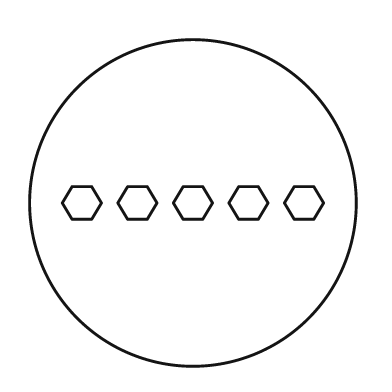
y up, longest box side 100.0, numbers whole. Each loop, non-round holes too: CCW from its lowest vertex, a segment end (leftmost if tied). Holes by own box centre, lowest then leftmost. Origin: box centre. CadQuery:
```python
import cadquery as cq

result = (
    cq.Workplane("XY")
    .moveTo(0.0, 0.0)
    .circle(50.0)
    .moveTo(-37.0, -5.0)
    .lineTo(-31.0, -5.0)
    .lineTo(-28.0, 0.0)
    .lineTo(-31.0, 5.0)
    .lineTo(-37.0, 5.0)
    .lineTo(-40.0, 0.0)
    .close()
    .moveTo(-20.0, -5.0)
    .lineTo(-14.0, -5.0)
    .lineTo(-11.0, 0.0)
    .lineTo(-14.0, 5.0)
    .lineTo(-20.0, 5.0)
    .lineTo(-23.0, 0.0)
    .close()
    .moveTo(-3.0, -5.0)
    .lineTo(3.0, -5.0)
    .lineTo(6.0, 0.0)
    .lineTo(3.0, 5.0)
    .lineTo(-3.0, 5.0)
    .lineTo(-6.0, 0.0)
    .close()
    .moveTo(14.0, -5.0)
    .lineTo(20.0, -5.0)
    .lineTo(23.0, 0.0)
    .lineTo(20.0, 5.0)
    .lineTo(14.0, 5.0)
    .lineTo(11.0, 0.0)
    .close()
    .moveTo(31.0, -5.0)
    .lineTo(37.0, -5.0)
    .lineTo(40.0, 0.0)
    .lineTo(37.0, 5.0)
    .lineTo(31.0, 5.0)
    .lineTo(28.0, 0.0)
    .close()
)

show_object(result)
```